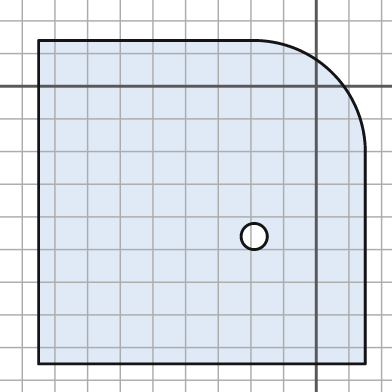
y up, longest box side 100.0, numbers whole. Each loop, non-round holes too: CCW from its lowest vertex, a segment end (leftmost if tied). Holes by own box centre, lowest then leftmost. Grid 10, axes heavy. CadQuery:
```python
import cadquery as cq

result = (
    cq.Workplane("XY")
    .moveTo(-85.0, -85.0)
    .lineTo(15.0, -85.0)
    .lineTo(15.0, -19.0)
    .threePointArc((5.0, 4.0), (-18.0, 14.0))
    .lineTo(-85.0, 14.0)
    .close()
    .moveTo(-19.0, -46.0)
    .circle(4.0)
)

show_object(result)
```